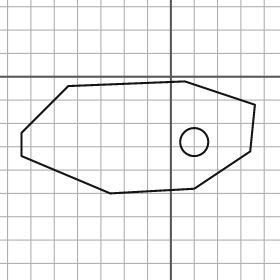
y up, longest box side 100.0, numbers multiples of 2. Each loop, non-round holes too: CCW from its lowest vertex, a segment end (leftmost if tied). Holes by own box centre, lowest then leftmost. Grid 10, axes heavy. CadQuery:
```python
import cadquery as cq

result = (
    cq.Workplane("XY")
    .moveTo(-26.0, -50.0)
    .lineTo(10.0, -48.0)
    .lineTo(34.0, -32.0)
    .lineTo(36.0, -12.0)
    .lineTo(6.0, -2.0)
    .lineTo(-44.0, -4.0)
    .lineTo(-64.0, -24.0)
    .lineTo(-64.0, -34.0)
    .close()
    .moveTo(10.0, -28.0)
    .circle(6.0)
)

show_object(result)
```